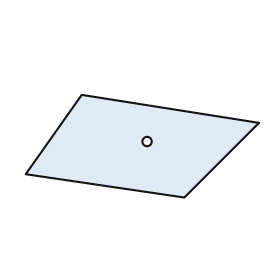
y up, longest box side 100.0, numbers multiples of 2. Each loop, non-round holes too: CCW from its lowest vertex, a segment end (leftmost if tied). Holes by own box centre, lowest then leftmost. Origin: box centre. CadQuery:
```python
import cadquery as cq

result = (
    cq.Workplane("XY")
    .moveTo(18.0, -22.0)
    .lineTo(50.0, 10.0)
    .lineTo(-26.0, 22.0)
    .lineTo(-50.0, -12.0)
    .close()
    .moveTo(2.0, 2.0)
    .circle(2.0)
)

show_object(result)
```